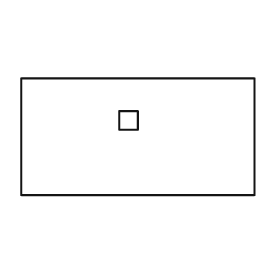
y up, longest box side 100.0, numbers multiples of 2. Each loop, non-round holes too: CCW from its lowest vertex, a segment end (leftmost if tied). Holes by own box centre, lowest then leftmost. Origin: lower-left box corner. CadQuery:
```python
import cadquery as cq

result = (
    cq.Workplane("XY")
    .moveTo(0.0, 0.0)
    .lineTo(100.0, 0.0)
    .lineTo(100.0, 50.0)
    .lineTo(0.0, 50.0)
    .close()
    .moveTo(42.0, 28.0)
    .lineTo(50.0, 28.0)
    .lineTo(50.0, 36.0)
    .lineTo(42.0, 36.0)
    .close()
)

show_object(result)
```